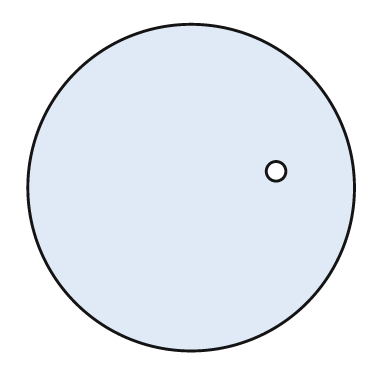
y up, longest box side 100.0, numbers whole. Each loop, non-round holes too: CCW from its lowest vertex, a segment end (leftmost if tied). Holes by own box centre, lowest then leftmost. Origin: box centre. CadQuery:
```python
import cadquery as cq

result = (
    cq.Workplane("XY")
    .moveTo(0.0, 0.0)
    .circle(50.0)
    .moveTo(26.0, 5.0)
    .circle(3.0)
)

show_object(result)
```